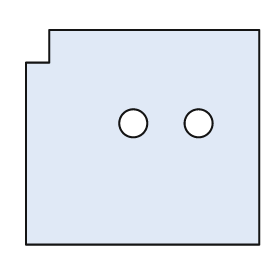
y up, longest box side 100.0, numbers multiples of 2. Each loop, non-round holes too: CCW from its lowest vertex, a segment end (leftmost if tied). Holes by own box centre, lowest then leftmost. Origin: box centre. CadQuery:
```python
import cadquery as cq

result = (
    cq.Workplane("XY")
    .moveTo(-50.0, -46.0)
    .lineTo(50.0, -46.0)
    .lineTo(50.0, 46.0)
    .lineTo(-40.0, 46.0)
    .lineTo(-40.0, 32.0)
    .lineTo(-50.0, 32.0)
    .close()
    .moveTo(-4.0, 6.0)
    .circle(6.0)
    .moveTo(24.0, 6.0)
    .circle(6.0)
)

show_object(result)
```